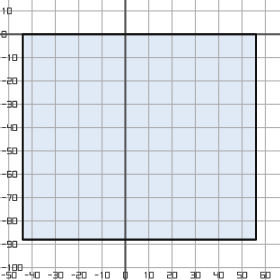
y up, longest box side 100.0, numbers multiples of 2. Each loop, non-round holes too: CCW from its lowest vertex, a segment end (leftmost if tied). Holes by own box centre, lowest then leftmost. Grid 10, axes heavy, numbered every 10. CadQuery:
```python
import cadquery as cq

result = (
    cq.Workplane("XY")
    .moveTo(-44.0, -88.0)
    .lineTo(56.0, -88.0)
    .lineTo(56.0, 0.0)
    .lineTo(-44.0, 0.0)
    .close()
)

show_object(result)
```